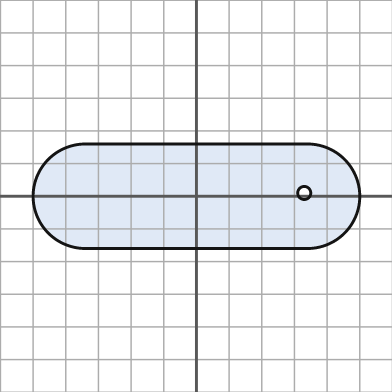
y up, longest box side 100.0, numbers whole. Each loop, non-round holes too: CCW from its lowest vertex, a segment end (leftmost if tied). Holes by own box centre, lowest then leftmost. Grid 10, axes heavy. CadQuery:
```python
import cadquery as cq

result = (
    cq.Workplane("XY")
    .moveTo(-34.0, -16.0)
    .lineTo(34.0, -16.0)
    .threePointArc((50.0, 0.0), (34.0, 16.0))
    .lineTo(-34.0, 16.0)
    .threePointArc((-50.0, 0.0), (-34.0, -16.0))
    .close()
    .moveTo(33.0, 1.0)
    .circle(2.0)
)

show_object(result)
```